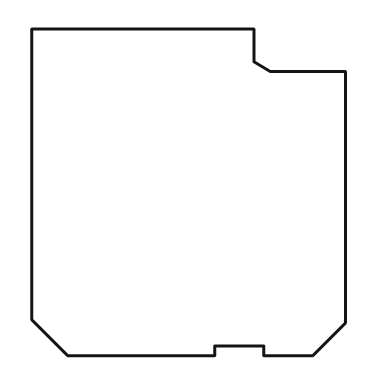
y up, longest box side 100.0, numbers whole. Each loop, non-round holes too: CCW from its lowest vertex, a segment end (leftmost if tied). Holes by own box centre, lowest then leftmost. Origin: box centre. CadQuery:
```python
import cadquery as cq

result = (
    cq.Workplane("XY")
    .moveTo(-37.0, -50.0)
    .lineTo(8.0, -50.0)
    .lineTo(8.0, -47.0)
    .lineTo(23.0, -47.0)
    .lineTo(23.0, -50.0)
    .lineTo(38.0, -50.0)
    .lineTo(48.0, -40.0)
    .lineTo(48.0, 37.0)
    .lineTo(25.0, 37.0)
    .lineTo(20.0, 40.0)
    .lineTo(20.0, 50.0)
    .lineTo(-48.0, 50.0)
    .lineTo(-48.0, -39.0)
    .close()
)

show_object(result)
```